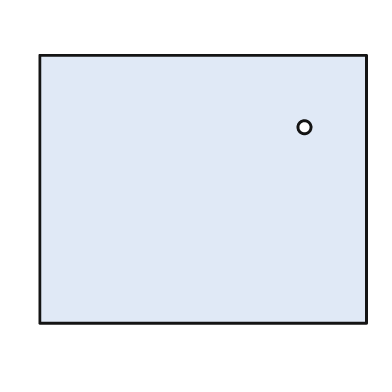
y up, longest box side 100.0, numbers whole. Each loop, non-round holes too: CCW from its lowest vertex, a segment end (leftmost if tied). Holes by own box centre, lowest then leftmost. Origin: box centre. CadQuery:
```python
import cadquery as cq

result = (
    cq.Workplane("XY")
    .moveTo(-50.0, -41.0)
    .lineTo(50.0, -41.0)
    .lineTo(50.0, 41.0)
    .lineTo(-50.0, 41.0)
    .close()
    .moveTo(31.0, 19.0)
    .circle(2.0)
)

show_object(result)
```